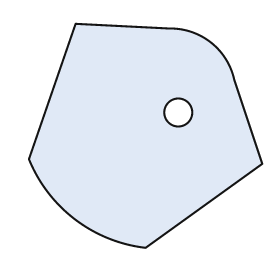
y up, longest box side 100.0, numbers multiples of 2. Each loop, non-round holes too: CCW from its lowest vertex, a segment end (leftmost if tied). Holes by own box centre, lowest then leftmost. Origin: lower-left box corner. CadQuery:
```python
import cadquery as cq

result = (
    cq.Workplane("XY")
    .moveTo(50.0, 0.0)
    .lineTo(100.0, 36.0)
    .lineTo(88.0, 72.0)
    .threePointArc((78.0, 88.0), (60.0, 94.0))
    .lineTo(20.0, 96.0)
    .lineTo(0.0, 38.0)
    .threePointArc((20.0, 12.0), (50.0, 0.0))
    .close()
    .moveTo(64.0, 58.0)
    .circle(6.0)
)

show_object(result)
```